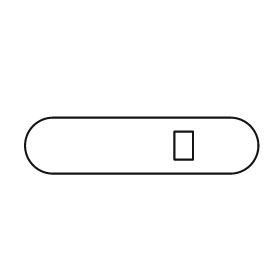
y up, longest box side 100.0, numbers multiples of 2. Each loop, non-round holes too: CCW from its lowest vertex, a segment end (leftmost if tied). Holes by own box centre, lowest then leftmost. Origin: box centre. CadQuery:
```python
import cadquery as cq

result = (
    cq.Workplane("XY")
    .moveTo(-38.0, -12.0)
    .lineTo(38.0, -12.0)
    .threePointArc((50.0, 0.0), (38.0, 12.0))
    .lineTo(-38.0, 12.0)
    .threePointArc((-50.0, 0.0), (-38.0, -12.0))
    .close()
    .moveTo(14.0, -6.0)
    .lineTo(22.0, -6.0)
    .lineTo(22.0, 6.0)
    .lineTo(14.0, 6.0)
    .close()
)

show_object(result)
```